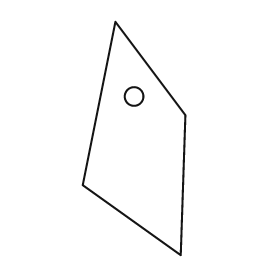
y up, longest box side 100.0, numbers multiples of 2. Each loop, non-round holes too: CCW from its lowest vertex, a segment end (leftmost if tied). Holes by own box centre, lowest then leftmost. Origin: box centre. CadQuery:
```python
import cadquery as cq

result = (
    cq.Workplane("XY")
    .moveTo(20.0, -50.0)
    .lineTo(22.0, 10.0)
    .lineTo(-8.0, 50.0)
    .lineTo(-22.0, -20.0)
    .close()
    .moveTo(0.0, 18.0)
    .circle(4.0)
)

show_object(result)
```